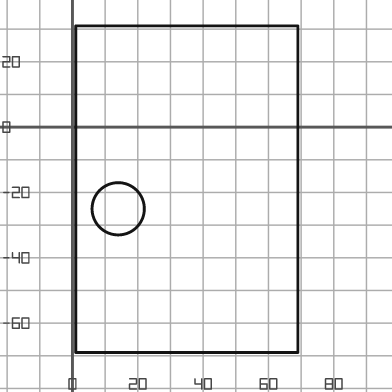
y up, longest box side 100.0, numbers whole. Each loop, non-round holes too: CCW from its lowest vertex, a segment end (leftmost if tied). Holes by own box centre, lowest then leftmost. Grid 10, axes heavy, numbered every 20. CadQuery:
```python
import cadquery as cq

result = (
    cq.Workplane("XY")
    .moveTo(1.0, -69.0)
    .lineTo(69.0, -69.0)
    .lineTo(69.0, 31.0)
    .lineTo(1.0, 31.0)
    .close()
    .moveTo(14.0, -25.0)
    .circle(8.0)
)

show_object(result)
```